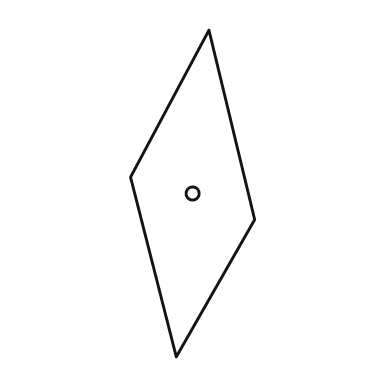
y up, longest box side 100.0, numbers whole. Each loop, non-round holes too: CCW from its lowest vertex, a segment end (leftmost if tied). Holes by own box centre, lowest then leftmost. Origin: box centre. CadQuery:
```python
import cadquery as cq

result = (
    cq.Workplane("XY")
    .moveTo(-5.0, -50.0)
    .lineTo(19.0, -8.0)
    .lineTo(5.0, 50.0)
    .lineTo(-19.0, 5.0)
    .close()
    .moveTo(0.0, 0.0)
    .circle(2.0)
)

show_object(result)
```